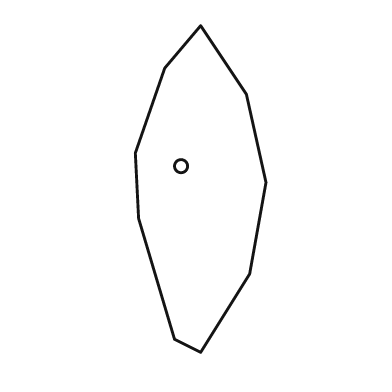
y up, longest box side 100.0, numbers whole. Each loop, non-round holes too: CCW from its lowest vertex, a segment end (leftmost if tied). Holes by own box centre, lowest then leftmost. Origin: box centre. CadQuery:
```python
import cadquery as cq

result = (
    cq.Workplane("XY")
    .moveTo(0.0, -50.0)
    .lineTo(15.0, -26.0)
    .lineTo(20.0, 2.0)
    .lineTo(14.0, 29.0)
    .lineTo(0.0, 50.0)
    .lineTo(-11.0, 37.0)
    .lineTo(-20.0, 11.0)
    .lineTo(-19.0, -9.0)
    .lineTo(-8.0, -46.0)
    .close()
    .moveTo(-6.0, 7.0)
    .circle(2.0)
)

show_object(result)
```